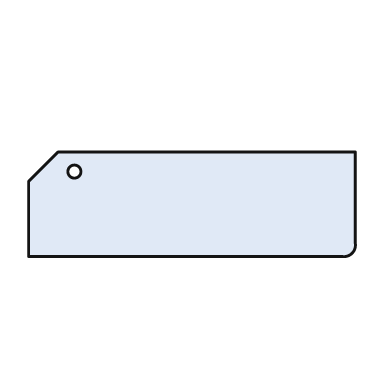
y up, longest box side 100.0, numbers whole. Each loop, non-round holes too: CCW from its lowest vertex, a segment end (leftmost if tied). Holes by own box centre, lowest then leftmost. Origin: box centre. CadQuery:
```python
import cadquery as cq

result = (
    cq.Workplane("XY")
    .moveTo(-50.0, -16.0)
    .lineTo(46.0, -16.0)
    .threePointArc((49.0, -15.0), (50.0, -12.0))
    .lineTo(50.0, 16.0)
    .lineTo(-41.0, 16.0)
    .lineTo(-50.0, 7.0)
    .close()
    .moveTo(-36.0, 10.0)
    .circle(2.0)
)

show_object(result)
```